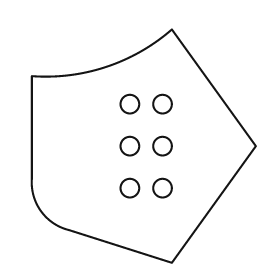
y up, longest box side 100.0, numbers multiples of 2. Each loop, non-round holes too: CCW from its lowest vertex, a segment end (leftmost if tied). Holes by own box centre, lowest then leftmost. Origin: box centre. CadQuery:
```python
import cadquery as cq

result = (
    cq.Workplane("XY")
    .moveTo(12.0, -50.0)
    .lineTo(48.0, 0.0)
    .lineTo(12.0, 50.0)
    .threePointArc((-16.0, 34.0), (-48.0, 30.0))
    .lineTo(-48.0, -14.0)
    .threePointArc((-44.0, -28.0), (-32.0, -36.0))
    .close()
    .moveTo(-6.0, -18.0)
    .circle(4.0)
    .moveTo(8.0, -18.0)
    .circle(4.0)
    .moveTo(-6.0, 0.0)
    .circle(4.0)
    .moveTo(8.0, 0.0)
    .circle(4.0)
    .moveTo(-6.0, 18.0)
    .circle(4.0)
    .moveTo(8.0, 18.0)
    .circle(4.0)
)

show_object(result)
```